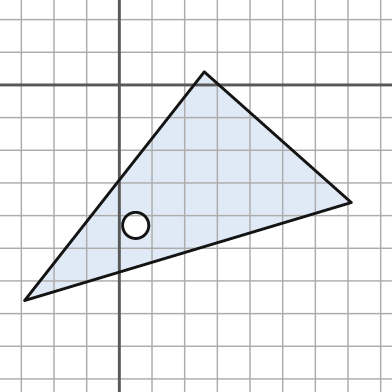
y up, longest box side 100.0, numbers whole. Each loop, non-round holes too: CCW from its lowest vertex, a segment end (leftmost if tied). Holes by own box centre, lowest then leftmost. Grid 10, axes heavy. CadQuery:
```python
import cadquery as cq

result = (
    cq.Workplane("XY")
    .moveTo(-29.0, -66.0)
    .lineTo(71.0, -36.0)
    .lineTo(26.0, 4.0)
    .close()
    .moveTo(5.0, -43.0)
    .circle(4.0)
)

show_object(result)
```